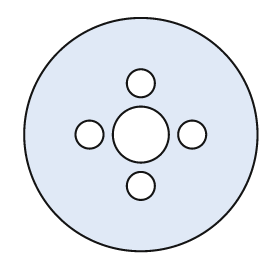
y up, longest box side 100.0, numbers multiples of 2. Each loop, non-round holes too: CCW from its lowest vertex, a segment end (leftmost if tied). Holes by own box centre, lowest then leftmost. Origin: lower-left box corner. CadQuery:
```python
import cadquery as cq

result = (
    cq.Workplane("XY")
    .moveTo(50.0, 50.0)
    .circle(50.0)
    .moveTo(50.0, 28.0)
    .circle(6.0)
    .moveTo(28.0, 50.0)
    .circle(6.0)
    .moveTo(50.0, 50.0)
    .circle(12.0)
    .moveTo(72.0, 50.0)
    .circle(6.0)
    .moveTo(50.0, 72.0)
    .circle(6.0)
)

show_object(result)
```